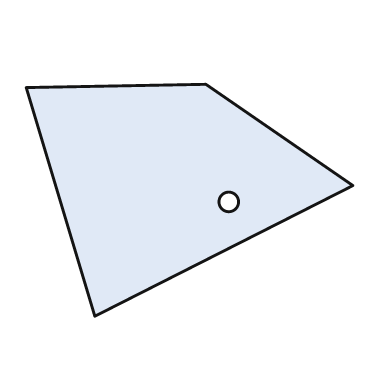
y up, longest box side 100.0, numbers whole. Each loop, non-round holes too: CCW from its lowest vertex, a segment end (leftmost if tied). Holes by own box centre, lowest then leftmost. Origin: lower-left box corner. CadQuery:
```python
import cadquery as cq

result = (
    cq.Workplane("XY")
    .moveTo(21.0, 0.0)
    .lineTo(100.0, 40.0)
    .lineTo(55.0, 71.0)
    .lineTo(0.0, 70.0)
    .close()
    .moveTo(62.0, 35.0)
    .circle(3.0)
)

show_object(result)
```